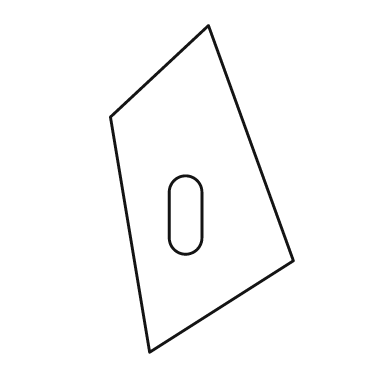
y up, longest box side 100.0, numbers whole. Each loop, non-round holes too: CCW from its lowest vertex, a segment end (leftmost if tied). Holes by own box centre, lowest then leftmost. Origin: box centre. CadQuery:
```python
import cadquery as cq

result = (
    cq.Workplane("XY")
    .moveTo(-16.0, -50.0)
    .lineTo(28.0, -22.0)
    .lineTo(2.0, 50.0)
    .lineTo(-28.0, 22.0)
    .close()
    .moveTo(-10.0, -15.0)
    .threePointArc((-5.0, -20.0), (0.0, -15.0))
    .lineTo(0.0, -1.0)
    .threePointArc((-5.0, 4.0), (-10.0, -1.0))
    .close()
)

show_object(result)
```